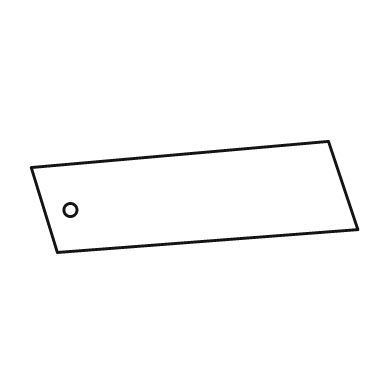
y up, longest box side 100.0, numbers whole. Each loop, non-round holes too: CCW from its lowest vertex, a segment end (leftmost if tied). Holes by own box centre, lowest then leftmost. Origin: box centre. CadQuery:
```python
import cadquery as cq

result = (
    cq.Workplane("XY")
    .moveTo(-42.0, -17.0)
    .lineTo(50.0, -10.0)
    .lineTo(41.0, 17.0)
    .lineTo(-50.0, 9.0)
    .close()
    .moveTo(-38.0, -4.0)
    .circle(2.0)
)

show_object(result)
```